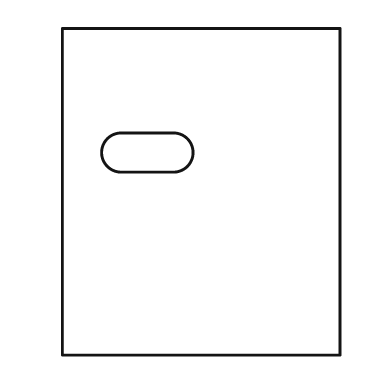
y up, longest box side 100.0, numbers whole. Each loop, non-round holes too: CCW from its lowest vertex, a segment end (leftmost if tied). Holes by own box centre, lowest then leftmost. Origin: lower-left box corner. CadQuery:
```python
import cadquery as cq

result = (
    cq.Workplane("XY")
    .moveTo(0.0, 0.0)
    .lineTo(85.0, 0.0)
    .lineTo(85.0, 100.0)
    .lineTo(0.0, 100.0)
    .close()
    .moveTo(18.0, 56.0)
    .lineTo(34.0, 56.0)
    .threePointArc((40.0, 62.0), (34.0, 68.0))
    .lineTo(18.0, 68.0)
    .threePointArc((12.0, 62.0), (18.0, 56.0))
    .close()
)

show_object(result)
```